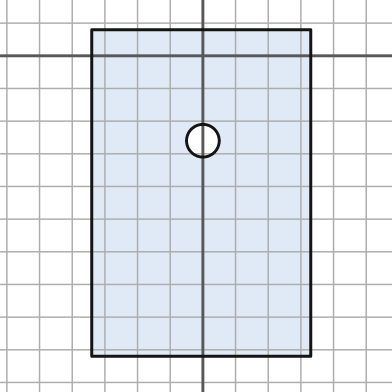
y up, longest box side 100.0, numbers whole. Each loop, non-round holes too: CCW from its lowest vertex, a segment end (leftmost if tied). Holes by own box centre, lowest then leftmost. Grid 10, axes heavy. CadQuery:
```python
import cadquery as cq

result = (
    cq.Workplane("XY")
    .moveTo(-34.0, -92.0)
    .lineTo(33.0, -92.0)
    .lineTo(33.0, 8.0)
    .lineTo(-34.0, 8.0)
    .close()
    .moveTo(0.0, -26.0)
    .circle(5.0)
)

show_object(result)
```